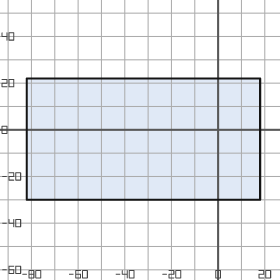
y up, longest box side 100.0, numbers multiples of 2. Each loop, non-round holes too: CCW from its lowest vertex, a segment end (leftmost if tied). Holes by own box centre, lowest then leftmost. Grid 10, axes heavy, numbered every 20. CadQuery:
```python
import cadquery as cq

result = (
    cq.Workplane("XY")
    .moveTo(-82.0, -30.0)
    .lineTo(18.0, -30.0)
    .lineTo(18.0, 22.0)
    .lineTo(-82.0, 22.0)
    .close()
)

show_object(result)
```